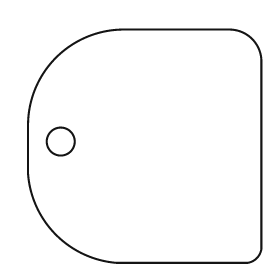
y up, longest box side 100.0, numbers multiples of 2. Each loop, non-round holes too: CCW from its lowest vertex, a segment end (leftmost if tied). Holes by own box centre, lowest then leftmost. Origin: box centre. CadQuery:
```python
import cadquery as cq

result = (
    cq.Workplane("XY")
    .moveTo(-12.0, -50.0)
    .lineTo(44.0, -50.0)
    .threePointArc((48.0, -48.0), (50.0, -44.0))
    .lineTo(50.0, 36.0)
    .threePointArc((46.0, 46.0), (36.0, 50.0))
    .lineTo(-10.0, 50.0)
    .threePointArc((-38.0, 38.0), (-50.0, 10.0))
    .lineTo(-50.0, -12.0)
    .threePointArc((-38.0, -38.0), (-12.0, -50.0))
    .close()
    .moveTo(-36.0, 2.0)
    .circle(6.0)
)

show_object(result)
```